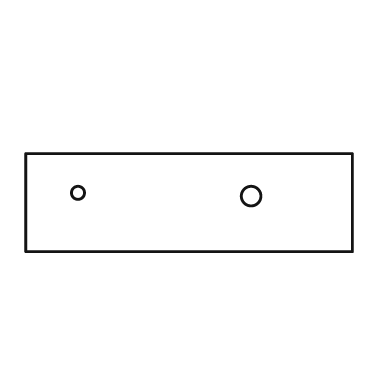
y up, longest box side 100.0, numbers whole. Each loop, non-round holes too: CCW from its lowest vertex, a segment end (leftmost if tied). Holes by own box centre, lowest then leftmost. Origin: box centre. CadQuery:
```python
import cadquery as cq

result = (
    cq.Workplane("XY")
    .moveTo(-50.0, -15.0)
    .lineTo(50.0, -15.0)
    .lineTo(50.0, 15.0)
    .lineTo(-50.0, 15.0)
    .close()
    .moveTo(19.0, 2.0)
    .circle(3.0)
    .moveTo(-34.0, 3.0)
    .circle(2.0)
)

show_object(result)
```